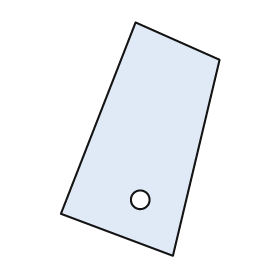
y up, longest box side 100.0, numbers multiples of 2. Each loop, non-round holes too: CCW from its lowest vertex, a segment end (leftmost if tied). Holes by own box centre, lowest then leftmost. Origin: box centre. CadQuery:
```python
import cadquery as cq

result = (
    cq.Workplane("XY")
    .moveTo(14.0, -50.0)
    .lineTo(34.0, 34.0)
    .lineTo(-2.0, 50.0)
    .lineTo(-34.0, -32.0)
    .close()
    .moveTo(0.0, -26.0)
    .circle(4.0)
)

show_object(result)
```